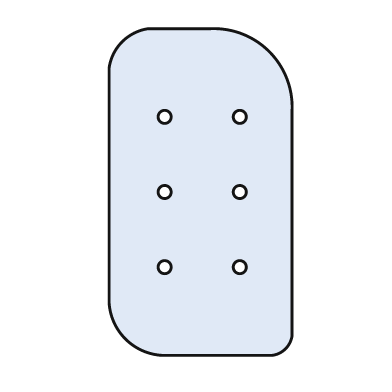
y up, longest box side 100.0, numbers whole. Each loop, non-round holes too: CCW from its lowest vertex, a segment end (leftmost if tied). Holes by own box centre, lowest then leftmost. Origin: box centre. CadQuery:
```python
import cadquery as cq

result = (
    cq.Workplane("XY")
    .moveTo(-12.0, -50.0)
    .lineTo(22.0, -50.0)
    .threePointArc((26.0, -48.0), (28.0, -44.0))
    .lineTo(28.0, 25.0)
    .threePointArc((21.0, 43.0), (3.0, 50.0))
    .lineTo(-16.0, 50.0)
    .threePointArc((-24.0, 46.0), (-28.0, 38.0))
    .lineTo(-28.0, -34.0)
    .threePointArc((-23.0, -45.0), (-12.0, -50.0))
    .close()
    .moveTo(-11.0, -23.0)
    .circle(2.0)
    .moveTo(12.0, -23.0)
    .circle(2.0)
    .moveTo(-11.0, 0.0)
    .circle(2.0)
    .moveTo(12.0, 0.0)
    .circle(2.0)
    .moveTo(-11.0, 23.0)
    .circle(2.0)
    .moveTo(12.0, 23.0)
    .circle(2.0)
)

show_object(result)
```